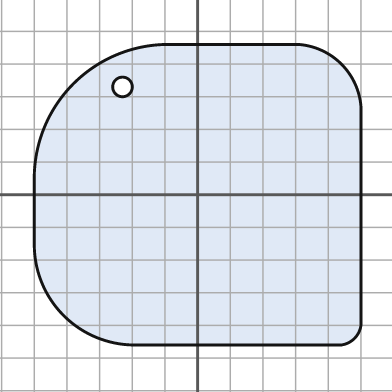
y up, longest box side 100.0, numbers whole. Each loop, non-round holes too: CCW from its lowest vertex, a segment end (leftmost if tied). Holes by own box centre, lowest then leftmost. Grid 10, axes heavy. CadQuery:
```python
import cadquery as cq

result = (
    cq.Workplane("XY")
    .moveTo(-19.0, -46.0)
    .lineTo(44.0, -46.0)
    .threePointArc((48.0, -44.0), (50.0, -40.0))
    .lineTo(50.0, 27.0)
    .threePointArc((44.0, 40.0), (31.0, 46.0))
    .lineTo(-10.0, 46.0)
    .threePointArc((-38.0, 34.0), (-50.0, 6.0))
    .lineTo(-50.0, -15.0)
    .threePointArc((-41.0, -37.0), (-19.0, -46.0))
    .close()
    .moveTo(-23.0, 33.0)
    .circle(3.0)
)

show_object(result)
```